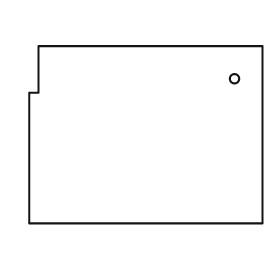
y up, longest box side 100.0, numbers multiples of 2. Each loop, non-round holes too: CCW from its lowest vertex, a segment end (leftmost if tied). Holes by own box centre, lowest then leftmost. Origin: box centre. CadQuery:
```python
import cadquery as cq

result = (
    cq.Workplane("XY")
    .moveTo(-50.0, -38.0)
    .lineTo(50.0, -38.0)
    .lineTo(50.0, 38.0)
    .lineTo(-46.0, 38.0)
    .lineTo(-46.0, 18.0)
    .lineTo(-50.0, 18.0)
    .close()
    .moveTo(38.0, 24.0)
    .circle(2.0)
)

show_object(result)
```